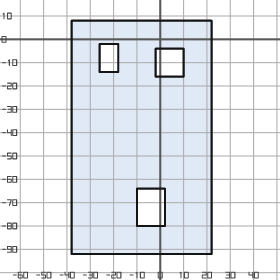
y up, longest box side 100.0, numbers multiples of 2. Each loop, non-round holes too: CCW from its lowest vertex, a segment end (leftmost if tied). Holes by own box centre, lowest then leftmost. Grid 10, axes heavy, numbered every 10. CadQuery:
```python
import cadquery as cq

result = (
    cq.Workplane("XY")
    .moveTo(-38.0, -92.0)
    .lineTo(22.0, -92.0)
    .lineTo(22.0, 8.0)
    .lineTo(-38.0, 8.0)
    .close()
    .moveTo(-10.0, -80.0)
    .lineTo(2.0, -80.0)
    .lineTo(2.0, -64.0)
    .lineTo(-10.0, -64.0)
    .close()
    .moveTo(-2.0, -16.0)
    .lineTo(10.0, -16.0)
    .lineTo(10.0, -4.0)
    .lineTo(-2.0, -4.0)
    .close()
    .moveTo(-26.0, -14.0)
    .lineTo(-18.0, -14.0)
    .lineTo(-18.0, -2.0)
    .lineTo(-26.0, -2.0)
    .close()
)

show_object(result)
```